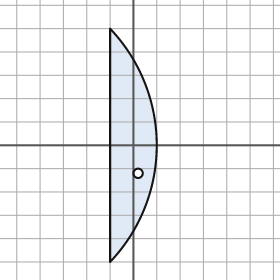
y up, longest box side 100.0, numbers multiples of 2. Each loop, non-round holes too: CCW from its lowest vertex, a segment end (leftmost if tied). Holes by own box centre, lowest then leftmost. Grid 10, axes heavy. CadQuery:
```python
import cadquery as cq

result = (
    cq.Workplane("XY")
    .moveTo(-10.0, -50.0)
    .threePointArc((10.0, 0.0), (-10.0, 50.0))
    .close()
    .moveTo(2.0, -12.0)
    .circle(2.0)
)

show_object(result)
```